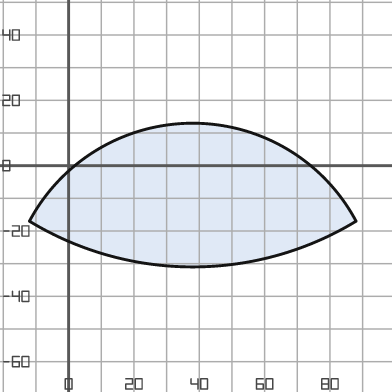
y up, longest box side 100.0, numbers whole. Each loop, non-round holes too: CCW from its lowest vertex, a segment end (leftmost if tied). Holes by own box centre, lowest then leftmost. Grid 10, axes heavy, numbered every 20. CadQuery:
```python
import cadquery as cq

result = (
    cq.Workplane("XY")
    .moveTo(-12.0, -17.0)
    .threePointArc((38.0, -31.0), (88.0, -17.0))
    .threePointArc((38.0, 13.0), (-12.0, -17.0))
    .close()
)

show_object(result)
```